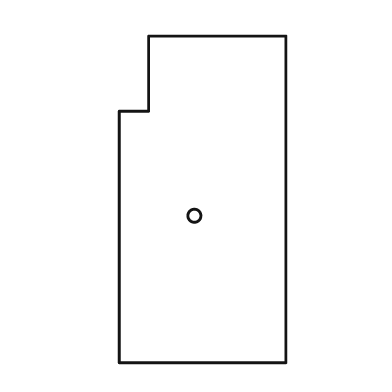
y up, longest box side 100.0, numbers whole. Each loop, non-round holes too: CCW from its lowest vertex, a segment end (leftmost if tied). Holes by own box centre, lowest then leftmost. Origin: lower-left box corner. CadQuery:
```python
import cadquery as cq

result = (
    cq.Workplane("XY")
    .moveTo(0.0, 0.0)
    .lineTo(51.0, 0.0)
    .lineTo(51.0, 100.0)
    .lineTo(9.0, 100.0)
    .lineTo(9.0, 77.0)
    .lineTo(0.0, 77.0)
    .close()
    .moveTo(23.0, 45.0)
    .circle(2.0)
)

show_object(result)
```